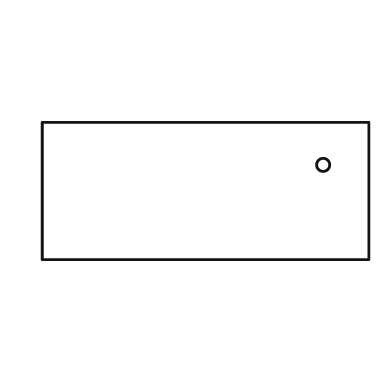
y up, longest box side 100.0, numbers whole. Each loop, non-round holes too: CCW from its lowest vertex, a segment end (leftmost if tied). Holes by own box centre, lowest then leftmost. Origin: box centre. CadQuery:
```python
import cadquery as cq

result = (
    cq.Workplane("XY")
    .moveTo(-50.0, -21.0)
    .lineTo(50.0, -21.0)
    .lineTo(50.0, 21.0)
    .lineTo(-50.0, 21.0)
    .close()
    .moveTo(36.0, 8.0)
    .circle(2.0)
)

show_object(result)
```